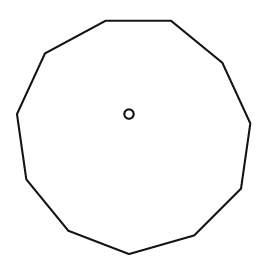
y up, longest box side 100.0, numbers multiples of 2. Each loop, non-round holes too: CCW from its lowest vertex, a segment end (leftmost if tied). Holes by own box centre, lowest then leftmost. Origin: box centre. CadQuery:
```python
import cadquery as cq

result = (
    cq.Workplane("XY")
    .moveTo(-2.0, -50.0)
    .lineTo(26.0, -42.0)
    .lineTo(46.0, -22.0)
    .lineTo(50.0, 6.0)
    .lineTo(38.0, 32.0)
    .lineTo(16.0, 50.0)
    .lineTo(-12.0, 50.0)
    .lineTo(-38.0, 36.0)
    .lineTo(-50.0, 10.0)
    .lineTo(-46.0, -18.0)
    .lineTo(-28.0, -40.0)
    .close()
    .moveTo(-2.0, 10.0)
    .circle(2.0)
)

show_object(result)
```